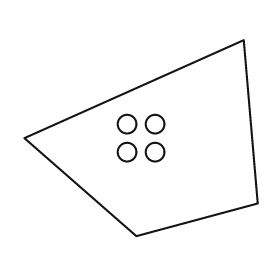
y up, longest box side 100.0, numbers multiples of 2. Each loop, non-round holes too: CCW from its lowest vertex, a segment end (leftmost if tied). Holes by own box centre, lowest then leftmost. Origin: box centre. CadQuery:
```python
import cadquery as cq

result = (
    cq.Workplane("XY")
    .moveTo(-2.0, -42.0)
    .lineTo(50.0, -28.0)
    .lineTo(44.0, 42.0)
    .lineTo(-50.0, 0.0)
    .close()
    .moveTo(-6.0, -6.0)
    .circle(4.0)
    .moveTo(6.0, -6.0)
    .circle(4.0)
    .moveTo(-6.0, 6.0)
    .circle(4.0)
    .moveTo(6.0, 6.0)
    .circle(4.0)
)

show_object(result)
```